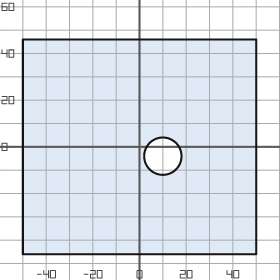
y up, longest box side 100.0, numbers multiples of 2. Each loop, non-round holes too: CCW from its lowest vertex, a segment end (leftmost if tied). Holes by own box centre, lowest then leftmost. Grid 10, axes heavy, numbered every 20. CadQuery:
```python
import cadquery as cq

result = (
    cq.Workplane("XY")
    .moveTo(-50.0, -46.0)
    .lineTo(50.0, -46.0)
    .lineTo(50.0, 46.0)
    .lineTo(-50.0, 46.0)
    .close()
    .moveTo(10.0, -4.0)
    .circle(8.0)
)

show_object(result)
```